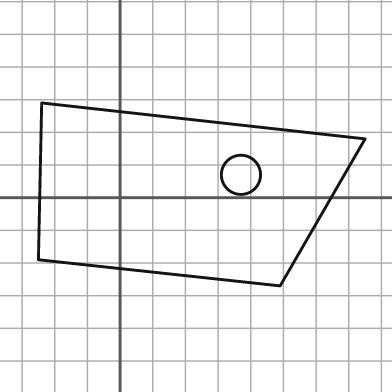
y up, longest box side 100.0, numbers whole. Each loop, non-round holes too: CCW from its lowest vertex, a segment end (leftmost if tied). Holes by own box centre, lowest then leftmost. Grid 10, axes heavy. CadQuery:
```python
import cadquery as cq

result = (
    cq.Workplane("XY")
    .moveTo(49.0, -27.0)
    .lineTo(75.0, 18.0)
    .lineTo(-24.0, 29.0)
    .lineTo(-25.0, -19.0)
    .close()
    .moveTo(37.0, 7.0)
    .circle(6.0)
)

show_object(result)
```